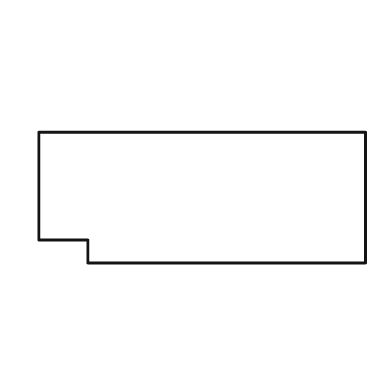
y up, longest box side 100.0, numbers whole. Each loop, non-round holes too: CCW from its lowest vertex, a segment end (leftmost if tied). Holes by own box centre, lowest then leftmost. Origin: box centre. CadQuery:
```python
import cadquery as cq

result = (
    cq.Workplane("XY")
    .moveTo(-35.0, -20.0)
    .lineTo(50.0, -20.0)
    .lineTo(50.0, 20.0)
    .lineTo(-50.0, 20.0)
    .lineTo(-50.0, -13.0)
    .lineTo(-35.0, -13.0)
    .close()
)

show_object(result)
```